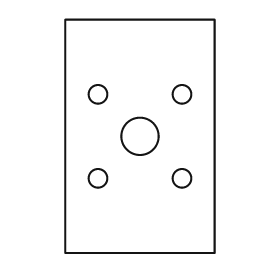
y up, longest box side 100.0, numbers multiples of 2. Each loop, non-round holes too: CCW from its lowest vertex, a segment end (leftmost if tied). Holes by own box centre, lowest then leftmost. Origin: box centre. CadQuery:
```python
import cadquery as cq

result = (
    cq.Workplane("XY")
    .moveTo(-32.0, -50.0)
    .lineTo(32.0, -50.0)
    .lineTo(32.0, 50.0)
    .lineTo(-32.0, 50.0)
    .close()
    .moveTo(-18.0, -18.0)
    .circle(4.0)
    .moveTo(18.0, -18.0)
    .circle(4.0)
    .moveTo(0.0, 0.0)
    .circle(8.0)
    .moveTo(-18.0, 18.0)
    .circle(4.0)
    .moveTo(18.0, 18.0)
    .circle(4.0)
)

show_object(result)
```